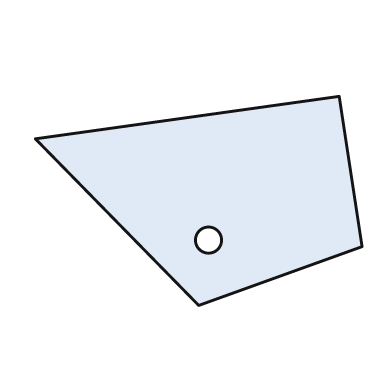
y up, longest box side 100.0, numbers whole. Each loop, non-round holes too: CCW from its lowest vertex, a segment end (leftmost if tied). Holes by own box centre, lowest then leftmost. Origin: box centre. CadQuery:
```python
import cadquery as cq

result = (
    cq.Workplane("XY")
    .moveTo(0.0, -32.0)
    .lineTo(50.0, -14.0)
    .lineTo(43.0, 32.0)
    .lineTo(-50.0, 19.0)
    .close()
    .moveTo(3.0, -12.0)
    .circle(4.0)
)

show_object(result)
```